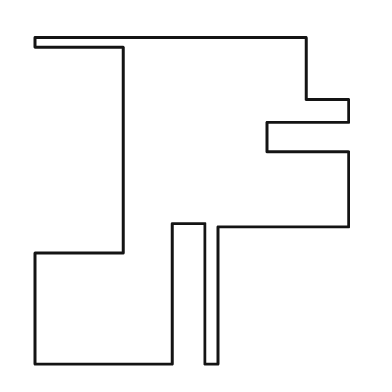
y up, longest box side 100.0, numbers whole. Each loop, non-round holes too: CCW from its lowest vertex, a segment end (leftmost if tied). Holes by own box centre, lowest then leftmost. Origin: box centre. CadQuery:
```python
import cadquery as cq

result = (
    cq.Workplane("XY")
    .moveTo(-48.0, -50.0)
    .lineTo(-6.0, -50.0)
    .lineTo(-6.0, -7.0)
    .lineTo(4.0, -7.0)
    .lineTo(4.0, -50.0)
    .lineTo(8.0, -50.0)
    .lineTo(8.0, -8.0)
    .lineTo(48.0, -8.0)
    .lineTo(48.0, 15.0)
    .lineTo(23.0, 15.0)
    .lineTo(23.0, 24.0)
    .lineTo(48.0, 24.0)
    .lineTo(48.0, 31.0)
    .lineTo(35.0, 31.0)
    .lineTo(35.0, 50.0)
    .lineTo(-48.0, 50.0)
    .lineTo(-48.0, 47.0)
    .lineTo(-21.0, 47.0)
    .lineTo(-21.0, -16.0)
    .lineTo(-48.0, -16.0)
    .close()
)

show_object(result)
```